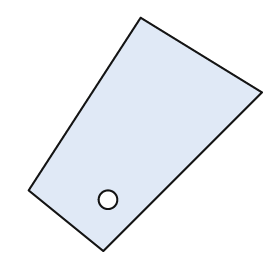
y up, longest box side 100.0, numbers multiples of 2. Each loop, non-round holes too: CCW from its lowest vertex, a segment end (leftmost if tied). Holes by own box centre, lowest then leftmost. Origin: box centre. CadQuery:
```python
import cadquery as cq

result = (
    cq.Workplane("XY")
    .moveTo(-18.0, -50.0)
    .lineTo(50.0, 18.0)
    .lineTo(-2.0, 50.0)
    .lineTo(-50.0, -24.0)
    .close()
    .moveTo(-16.0, -28.0)
    .circle(4.0)
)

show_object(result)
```